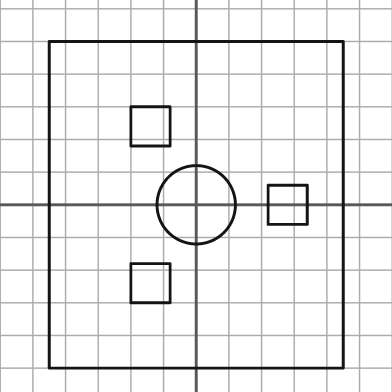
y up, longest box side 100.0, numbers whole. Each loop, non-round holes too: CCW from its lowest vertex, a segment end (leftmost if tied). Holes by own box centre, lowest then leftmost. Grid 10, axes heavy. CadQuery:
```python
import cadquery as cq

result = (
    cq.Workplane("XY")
    .moveTo(-45.0, -50.0)
    .lineTo(45.0, -50.0)
    .lineTo(45.0, 50.0)
    .lineTo(-45.0, 50.0)
    .close()
    .moveTo(-20.0, -30.0)
    .lineTo(-8.0, -30.0)
    .lineTo(-8.0, -18.0)
    .lineTo(-20.0, -18.0)
    .close()
    .moveTo(0.0, 0.0)
    .circle(12.0)
    .moveTo(22.0, -6.0)
    .lineTo(34.0, -6.0)
    .lineTo(34.0, 6.0)
    .lineTo(22.0, 6.0)
    .close()
    .moveTo(-20.0, 18.0)
    .lineTo(-8.0, 18.0)
    .lineTo(-8.0, 30.0)
    .lineTo(-20.0, 30.0)
    .close()
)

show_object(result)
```